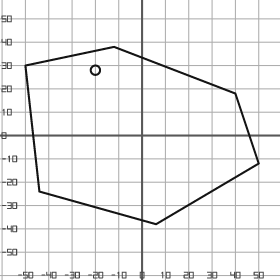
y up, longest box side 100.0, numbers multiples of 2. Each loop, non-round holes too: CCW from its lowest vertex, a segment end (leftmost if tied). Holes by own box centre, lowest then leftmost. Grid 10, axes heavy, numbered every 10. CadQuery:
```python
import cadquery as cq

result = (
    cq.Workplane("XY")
    .moveTo(6.0, -38.0)
    .lineTo(50.0, -12.0)
    .lineTo(40.0, 18.0)
    .lineTo(-12.0, 38.0)
    .lineTo(-50.0, 30.0)
    .lineTo(-44.0, -24.0)
    .close()
    .moveTo(-20.0, 28.0)
    .circle(2.0)
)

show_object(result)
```